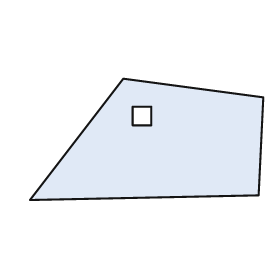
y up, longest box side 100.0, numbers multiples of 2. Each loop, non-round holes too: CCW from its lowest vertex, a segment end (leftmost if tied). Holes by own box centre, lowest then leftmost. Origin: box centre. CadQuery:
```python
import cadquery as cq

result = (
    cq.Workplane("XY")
    .moveTo(-50.0, -26.0)
    .lineTo(48.0, -24.0)
    .lineTo(50.0, 18.0)
    .lineTo(-10.0, 26.0)
    .close()
    .moveTo(-6.0, 6.0)
    .lineTo(2.0, 6.0)
    .lineTo(2.0, 14.0)
    .lineTo(-6.0, 14.0)
    .close()
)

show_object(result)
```